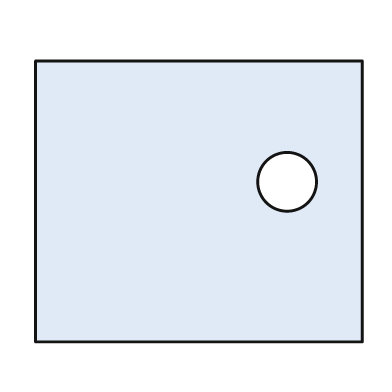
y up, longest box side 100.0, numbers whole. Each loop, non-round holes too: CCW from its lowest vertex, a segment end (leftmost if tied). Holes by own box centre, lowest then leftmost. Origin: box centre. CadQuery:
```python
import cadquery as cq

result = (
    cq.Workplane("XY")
    .moveTo(-50.0, -43.0)
    .lineTo(50.0, -43.0)
    .lineTo(50.0, 43.0)
    .lineTo(-50.0, 43.0)
    .close()
    .moveTo(27.0, 6.0)
    .circle(9.0)
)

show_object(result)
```